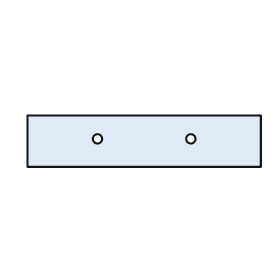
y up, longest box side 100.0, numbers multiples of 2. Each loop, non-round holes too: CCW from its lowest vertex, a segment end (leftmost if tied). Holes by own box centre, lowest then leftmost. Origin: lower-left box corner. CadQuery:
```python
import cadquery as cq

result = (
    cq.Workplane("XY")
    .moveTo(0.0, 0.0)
    .lineTo(100.0, 0.0)
    .lineTo(100.0, 22.0)
    .lineTo(0.0, 22.0)
    .close()
    .moveTo(30.0, 12.0)
    .circle(2.0)
    .moveTo(70.0, 12.0)
    .circle(2.0)
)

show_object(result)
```